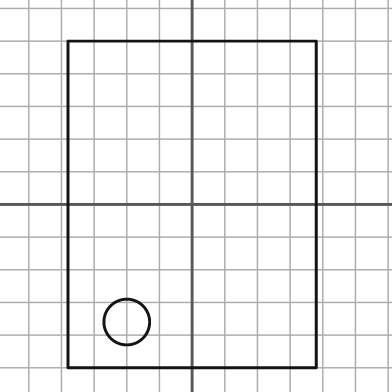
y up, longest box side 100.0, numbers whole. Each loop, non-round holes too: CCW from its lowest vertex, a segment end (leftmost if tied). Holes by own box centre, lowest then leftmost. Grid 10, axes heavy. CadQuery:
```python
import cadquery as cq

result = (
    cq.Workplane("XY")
    .moveTo(-38.0, -50.0)
    .lineTo(38.0, -50.0)
    .lineTo(38.0, 50.0)
    .lineTo(-38.0, 50.0)
    .close()
    .moveTo(-20.0, -36.0)
    .circle(7.0)
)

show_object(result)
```